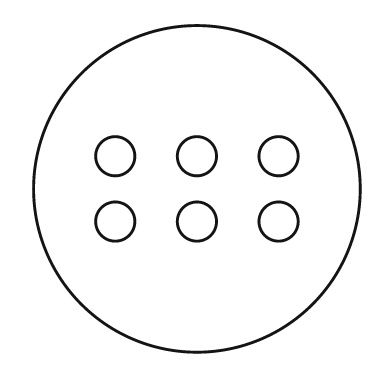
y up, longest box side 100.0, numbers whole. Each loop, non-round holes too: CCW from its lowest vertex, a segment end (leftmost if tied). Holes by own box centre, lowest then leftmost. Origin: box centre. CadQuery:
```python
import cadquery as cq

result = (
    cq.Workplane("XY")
    .moveTo(0.0, 0.0)
    .circle(50.0)
    .moveTo(-25.0, -10.0)
    .circle(6.0)
    .moveTo(0.0, -10.0)
    .circle(6.0)
    .moveTo(25.0, -10.0)
    .circle(6.0)
    .moveTo(-25.0, 10.0)
    .circle(6.0)
    .moveTo(0.0, 10.0)
    .circle(6.0)
    .moveTo(25.0, 10.0)
    .circle(6.0)
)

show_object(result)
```